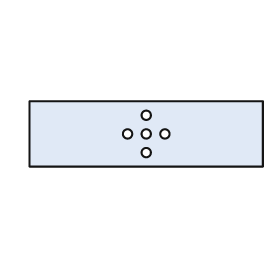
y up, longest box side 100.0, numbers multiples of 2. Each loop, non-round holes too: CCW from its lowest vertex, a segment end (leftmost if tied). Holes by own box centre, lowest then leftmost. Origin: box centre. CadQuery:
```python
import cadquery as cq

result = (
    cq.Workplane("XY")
    .moveTo(-50.0, -14.0)
    .lineTo(50.0, -14.0)
    .lineTo(50.0, 14.0)
    .lineTo(-50.0, 14.0)
    .close()
    .moveTo(0.0, -8.0)
    .circle(2.0)
    .moveTo(-8.0, 0.0)
    .circle(2.0)
    .moveTo(0.0, 0.0)
    .circle(2.0)
    .moveTo(8.0, 0.0)
    .circle(2.0)
    .moveTo(0.0, 8.0)
    .circle(2.0)
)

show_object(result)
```